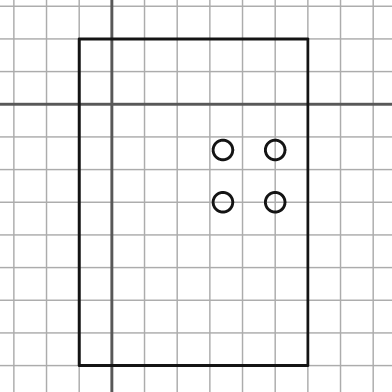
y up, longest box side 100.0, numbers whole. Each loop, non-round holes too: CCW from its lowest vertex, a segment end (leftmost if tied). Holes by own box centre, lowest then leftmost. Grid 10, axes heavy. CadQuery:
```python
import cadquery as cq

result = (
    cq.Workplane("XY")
    .moveTo(-10.0, -80.0)
    .lineTo(60.0, -80.0)
    .lineTo(60.0, 20.0)
    .lineTo(-10.0, 20.0)
    .close()
    .moveTo(34.0, -30.0)
    .circle(3.0)
    .moveTo(50.0, -30.0)
    .circle(3.0)
    .moveTo(34.0, -14.0)
    .circle(3.0)
    .moveTo(50.0, -14.0)
    .circle(3.0)
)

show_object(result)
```